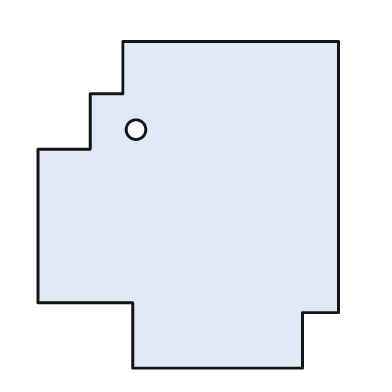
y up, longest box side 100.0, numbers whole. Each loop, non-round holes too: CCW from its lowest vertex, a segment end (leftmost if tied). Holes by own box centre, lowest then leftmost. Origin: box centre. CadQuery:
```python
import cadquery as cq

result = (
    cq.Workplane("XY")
    .moveTo(-17.0, -50.0)
    .lineTo(35.0, -50.0)
    .lineTo(35.0, -33.0)
    .lineTo(46.0, -33.0)
    .lineTo(46.0, 50.0)
    .lineTo(-20.0, 50.0)
    .lineTo(-20.0, 34.0)
    .lineTo(-30.0, 34.0)
    .lineTo(-30.0, 17.0)
    .lineTo(-46.0, 17.0)
    .lineTo(-46.0, -30.0)
    .lineTo(-17.0, -30.0)
    .close()
    .moveTo(-16.0, 23.0)
    .circle(3.0)
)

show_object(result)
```